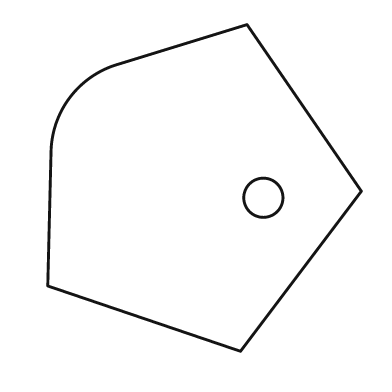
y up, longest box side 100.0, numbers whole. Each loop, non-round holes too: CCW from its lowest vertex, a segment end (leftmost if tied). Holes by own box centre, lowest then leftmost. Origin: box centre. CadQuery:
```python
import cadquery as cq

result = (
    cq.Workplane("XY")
    .moveTo(11.0, -50.0)
    .lineTo(48.0, -1.0)
    .lineTo(13.0, 50.0)
    .lineTo(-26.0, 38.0)
    .threePointArc((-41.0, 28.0), (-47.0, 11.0))
    .lineTo(-48.0, -30.0)
    .close()
    .moveTo(18.0, -3.0)
    .circle(6.0)
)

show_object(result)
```